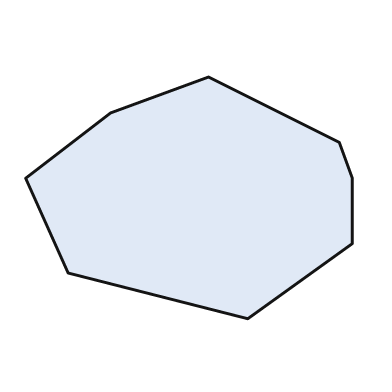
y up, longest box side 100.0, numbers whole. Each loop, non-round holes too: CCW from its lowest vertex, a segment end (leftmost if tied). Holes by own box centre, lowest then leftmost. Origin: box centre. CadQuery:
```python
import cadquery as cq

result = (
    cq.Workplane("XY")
    .moveTo(18.0, -37.0)
    .lineTo(50.0, -14.0)
    .lineTo(50.0, 6.0)
    .lineTo(46.0, 17.0)
    .lineTo(6.0, 37.0)
    .lineTo(-24.0, 26.0)
    .lineTo(-50.0, 6.0)
    .lineTo(-37.0, -23.0)
    .close()
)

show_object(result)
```